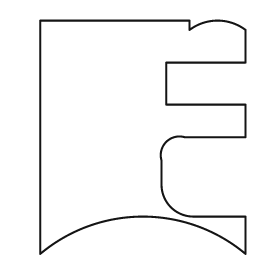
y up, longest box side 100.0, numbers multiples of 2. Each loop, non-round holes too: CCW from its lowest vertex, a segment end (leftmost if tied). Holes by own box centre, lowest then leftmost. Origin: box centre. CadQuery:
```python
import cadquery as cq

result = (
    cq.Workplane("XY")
    .moveTo(-44.0, -50.0)
    .threePointArc((0.0, -34.0), (44.0, -50.0))
    .lineTo(44.0, -34.0)
    .lineTo(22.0, -34.0)
    .threePointArc((12.0, -30.0), (8.0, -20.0))
    .lineTo(8.0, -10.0)
    .threePointArc((10.0, -2.0), (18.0, 0.0))
    .lineTo(44.0, 0.0)
    .lineTo(44.0, 14.0)
    .lineTo(10.0, 14.0)
    .lineTo(10.0, 32.0)
    .lineTo(44.0, 32.0)
    .lineTo(44.0, 46.0)
    .threePointArc((32.0, 50.0), (20.0, 46.0))
    .lineTo(20.0, 50.0)
    .lineTo(-44.0, 50.0)
    .close()
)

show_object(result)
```